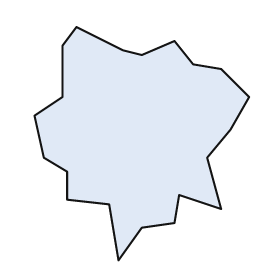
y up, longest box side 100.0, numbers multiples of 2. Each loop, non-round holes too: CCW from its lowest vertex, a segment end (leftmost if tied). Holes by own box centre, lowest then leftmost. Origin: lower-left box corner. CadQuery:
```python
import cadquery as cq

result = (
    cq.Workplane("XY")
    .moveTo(36.0, 0.0)
    .lineTo(46.0, 14.0)
    .lineTo(60.0, 16.0)
    .lineTo(62.0, 28.0)
    .lineTo(80.0, 22.0)
    .lineTo(74.0, 44.0)
    .lineTo(84.0, 56.0)
    .lineTo(92.0, 70.0)
    .lineTo(80.0, 82.0)
    .lineTo(68.0, 84.0)
    .lineTo(60.0, 94.0)
    .lineTo(46.0, 88.0)
    .lineTo(38.0, 90.0)
    .lineTo(18.0, 100.0)
    .lineTo(12.0, 92.0)
    .lineTo(12.0, 70.0)
    .lineTo(0.0, 62.0)
    .lineTo(4.0, 44.0)
    .lineTo(14.0, 38.0)
    .lineTo(14.0, 26.0)
    .lineTo(32.0, 24.0)
    .close()
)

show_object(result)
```